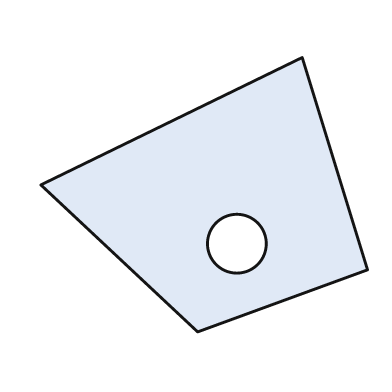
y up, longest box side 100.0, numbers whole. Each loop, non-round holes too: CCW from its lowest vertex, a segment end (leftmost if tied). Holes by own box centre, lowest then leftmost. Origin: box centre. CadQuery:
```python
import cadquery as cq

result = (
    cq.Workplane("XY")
    .moveTo(-2.0, -42.0)
    .lineTo(50.0, -23.0)
    .lineTo(30.0, 42.0)
    .lineTo(-50.0, 3.0)
    .close()
    .moveTo(10.0, -15.0)
    .circle(9.0)
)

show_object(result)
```